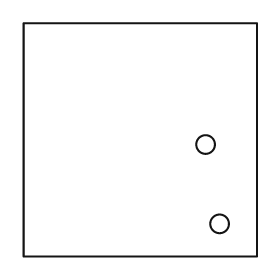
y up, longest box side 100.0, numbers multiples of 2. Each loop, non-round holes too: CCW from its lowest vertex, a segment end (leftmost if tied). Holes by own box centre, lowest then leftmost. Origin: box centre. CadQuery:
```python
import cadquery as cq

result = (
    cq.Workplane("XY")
    .moveTo(-50.0, -50.0)
    .lineTo(50.0, -50.0)
    .lineTo(50.0, 50.0)
    .lineTo(-50.0, 50.0)
    .close()
    .moveTo(34.0, -36.0)
    .circle(4.0)
    .moveTo(28.0, -2.0)
    .circle(4.0)
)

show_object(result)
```